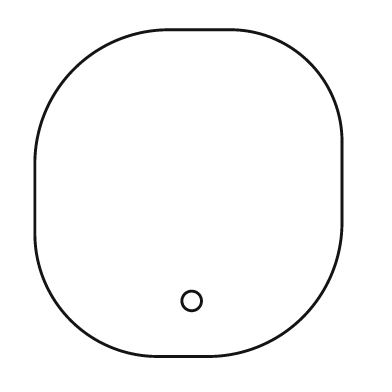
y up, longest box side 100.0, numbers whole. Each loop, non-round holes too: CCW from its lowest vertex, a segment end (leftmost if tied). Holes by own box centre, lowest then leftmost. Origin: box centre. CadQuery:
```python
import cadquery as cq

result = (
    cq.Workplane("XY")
    .moveTo(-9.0, -50.0)
    .lineTo(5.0, -50.0)
    .threePointArc((35.0, -38.0), (47.0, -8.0))
    .lineTo(47.0, 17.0)
    .threePointArc((37.0, 40.0), (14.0, 50.0))
    .lineTo(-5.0, 50.0)
    .threePointArc((-35.0, 38.0), (-47.0, 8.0))
    .lineTo(-47.0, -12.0)
    .threePointArc((-36.0, -39.0), (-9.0, -50.0))
    .close()
    .moveTo(1.0, -33.0)
    .circle(3.0)
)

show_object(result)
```